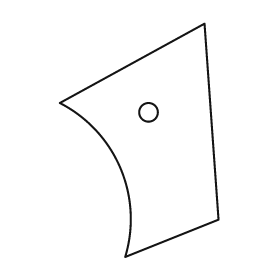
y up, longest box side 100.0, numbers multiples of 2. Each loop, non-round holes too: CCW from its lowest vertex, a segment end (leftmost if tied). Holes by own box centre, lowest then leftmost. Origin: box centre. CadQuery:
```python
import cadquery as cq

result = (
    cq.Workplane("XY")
    .moveTo(-6.0, -50.0)
    .lineTo(34.0, -34.0)
    .lineTo(28.0, 50.0)
    .lineTo(-34.0, 16.0)
    .threePointArc((-8.0, -12.0), (-6.0, -50.0))
    .close()
    .moveTo(4.0, 12.0)
    .circle(4.0)
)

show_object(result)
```